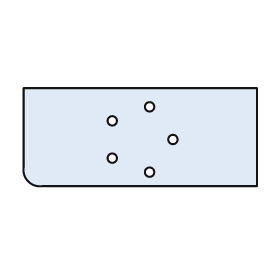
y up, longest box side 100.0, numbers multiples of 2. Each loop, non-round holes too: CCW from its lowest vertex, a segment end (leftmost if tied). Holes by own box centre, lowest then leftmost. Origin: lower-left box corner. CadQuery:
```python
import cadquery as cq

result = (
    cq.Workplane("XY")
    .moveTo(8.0, 0.0)
    .lineTo(100.0, 0.0)
    .lineTo(100.0, 42.0)
    .lineTo(0.0, 42.0)
    .lineTo(0.0, 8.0)
    .threePointArc((2.0, 2.0), (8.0, 0.0))
    .close()
    .moveTo(54.0, 6.0)
    .circle(2.0)
    .moveTo(38.0, 12.0)
    .circle(2.0)
    .moveTo(64.0, 20.0)
    .circle(2.0)
    .moveTo(38.0, 28.0)
    .circle(2.0)
    .moveTo(54.0, 34.0)
    .circle(2.0)
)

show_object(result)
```